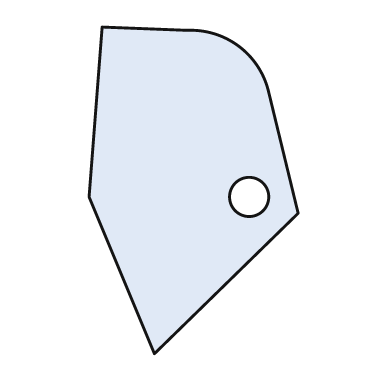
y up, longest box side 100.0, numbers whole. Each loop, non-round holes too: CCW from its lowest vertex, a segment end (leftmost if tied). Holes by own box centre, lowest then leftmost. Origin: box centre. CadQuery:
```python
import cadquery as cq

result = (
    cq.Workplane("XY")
    .moveTo(-12.0, -50.0)
    .lineTo(32.0, -7.0)
    .lineTo(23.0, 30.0)
    .threePointArc((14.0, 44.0), (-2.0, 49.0))
    .lineTo(-28.0, 50.0)
    .lineTo(-32.0, -2.0)
    .close()
    .moveTo(17.0, -2.0)
    .circle(6.0)
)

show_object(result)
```